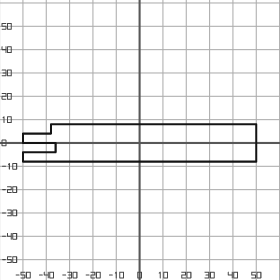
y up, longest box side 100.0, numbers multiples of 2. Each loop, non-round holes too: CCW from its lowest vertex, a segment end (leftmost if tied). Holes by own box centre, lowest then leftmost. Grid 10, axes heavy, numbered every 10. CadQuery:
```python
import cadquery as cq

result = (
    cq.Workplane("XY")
    .moveTo(-50.0, -8.0)
    .lineTo(50.0, -8.0)
    .lineTo(50.0, 8.0)
    .lineTo(-38.0, 8.0)
    .lineTo(-38.0, 4.0)
    .lineTo(-50.0, 4.0)
    .lineTo(-50.0, 0.0)
    .lineTo(-36.0, 0.0)
    .lineTo(-36.0, -4.0)
    .lineTo(-50.0, -4.0)
    .close()
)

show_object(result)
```